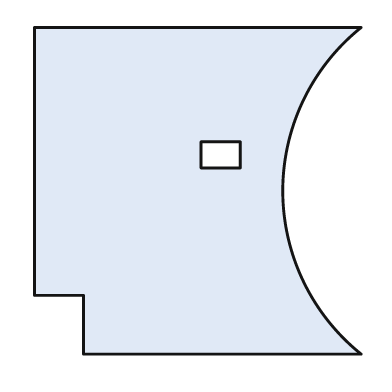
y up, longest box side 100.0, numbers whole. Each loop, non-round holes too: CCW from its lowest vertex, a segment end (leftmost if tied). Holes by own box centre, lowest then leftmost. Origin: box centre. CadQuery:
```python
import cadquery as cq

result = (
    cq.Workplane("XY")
    .moveTo(-35.0, -50.0)
    .lineTo(50.0, -50.0)
    .threePointArc((26.0, 0.0), (50.0, 50.0))
    .lineTo(-50.0, 50.0)
    .lineTo(-50.0, -32.0)
    .lineTo(-35.0, -32.0)
    .close()
    .moveTo(1.0, 7.0)
    .lineTo(13.0, 7.0)
    .lineTo(13.0, 15.0)
    .lineTo(1.0, 15.0)
    .close()
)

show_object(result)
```